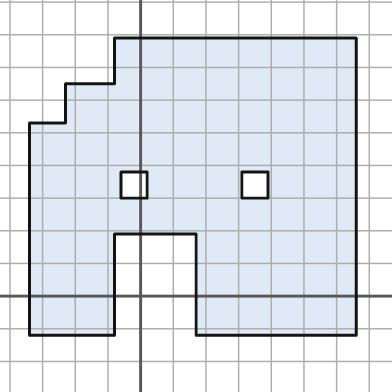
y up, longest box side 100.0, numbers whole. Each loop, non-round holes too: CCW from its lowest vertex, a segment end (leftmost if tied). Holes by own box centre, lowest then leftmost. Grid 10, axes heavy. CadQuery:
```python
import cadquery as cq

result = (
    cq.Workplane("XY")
    .moveTo(-34.0, -12.0)
    .lineTo(-8.0, -12.0)
    .lineTo(-8.0, 19.0)
    .lineTo(17.0, 19.0)
    .lineTo(17.0, -12.0)
    .lineTo(66.0, -12.0)
    .lineTo(66.0, 79.0)
    .lineTo(-8.0, 79.0)
    .lineTo(-8.0, 65.0)
    .lineTo(-23.0, 65.0)
    .lineTo(-23.0, 53.0)
    .lineTo(-34.0, 53.0)
    .close()
    .moveTo(-6.0, 30.0)
    .lineTo(2.0, 30.0)
    .lineTo(2.0, 38.0)
    .lineTo(-6.0, 38.0)
    .close()
    .moveTo(31.0, 30.0)
    .lineTo(39.0, 30.0)
    .lineTo(39.0, 38.0)
    .lineTo(31.0, 38.0)
    .close()
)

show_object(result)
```